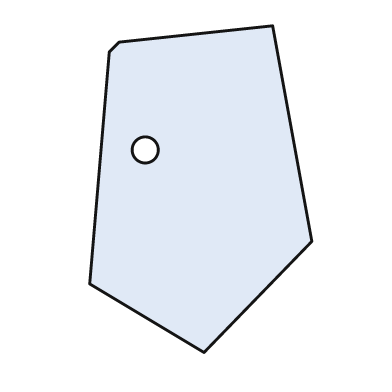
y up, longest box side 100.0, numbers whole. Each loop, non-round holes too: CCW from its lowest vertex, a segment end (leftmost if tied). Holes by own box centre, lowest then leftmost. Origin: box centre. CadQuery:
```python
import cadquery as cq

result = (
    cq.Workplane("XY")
    .moveTo(1.0, -50.0)
    .lineTo(34.0, -16.0)
    .lineTo(22.0, 50.0)
    .lineTo(-25.0, 45.0)
    .lineTo(-28.0, 42.0)
    .lineTo(-34.0, -29.0)
    .close()
    .moveTo(-17.0, 12.0)
    .circle(4.0)
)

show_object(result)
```